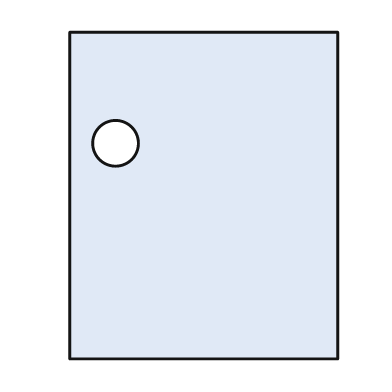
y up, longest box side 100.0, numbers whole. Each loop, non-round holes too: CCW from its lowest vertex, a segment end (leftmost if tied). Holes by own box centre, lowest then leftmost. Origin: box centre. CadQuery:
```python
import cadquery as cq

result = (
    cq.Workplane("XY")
    .moveTo(-41.0, -50.0)
    .lineTo(41.0, -50.0)
    .lineTo(41.0, 50.0)
    .lineTo(-41.0, 50.0)
    .close()
    .moveTo(-27.0, 16.0)
    .circle(7.0)
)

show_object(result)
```